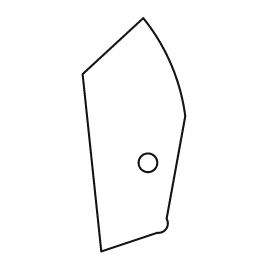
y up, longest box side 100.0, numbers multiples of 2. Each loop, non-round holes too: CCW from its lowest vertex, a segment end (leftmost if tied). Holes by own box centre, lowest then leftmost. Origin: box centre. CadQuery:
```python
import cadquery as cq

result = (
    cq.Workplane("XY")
    .moveTo(-14.0, -50.0)
    .lineTo(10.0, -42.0)
    .threePointArc((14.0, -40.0), (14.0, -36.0))
    .lineTo(22.0, 8.0)
    .threePointArc((16.0, 30.0), (4.0, 50.0))
    .lineTo(-22.0, 26.0)
    .close()
    .moveTo(6.0, -12.0)
    .circle(4.0)
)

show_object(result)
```